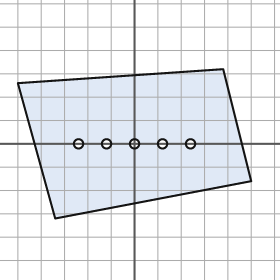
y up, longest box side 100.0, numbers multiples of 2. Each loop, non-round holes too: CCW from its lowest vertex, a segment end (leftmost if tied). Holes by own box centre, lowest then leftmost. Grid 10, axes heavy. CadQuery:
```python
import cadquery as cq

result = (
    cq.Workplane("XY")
    .moveTo(-34.0, -32.0)
    .lineTo(50.0, -16.0)
    .lineTo(38.0, 32.0)
    .lineTo(-50.0, 26.0)
    .close()
    .moveTo(-24.0, 0.0)
    .circle(2.0)
    .moveTo(-12.0, 0.0)
    .circle(2.0)
    .moveTo(0.0, 0.0)
    .circle(2.0)
    .moveTo(12.0, 0.0)
    .circle(2.0)
    .moveTo(24.0, 0.0)
    .circle(2.0)
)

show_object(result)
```